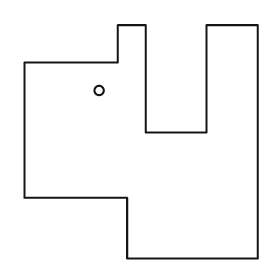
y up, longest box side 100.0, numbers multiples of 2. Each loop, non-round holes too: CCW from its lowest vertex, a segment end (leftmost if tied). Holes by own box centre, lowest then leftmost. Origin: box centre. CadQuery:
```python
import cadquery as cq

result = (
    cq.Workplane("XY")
    .moveTo(-6.0, -50.0)
    .lineTo(50.0, -50.0)
    .lineTo(50.0, 50.0)
    .lineTo(28.0, 50.0)
    .lineTo(28.0, 4.0)
    .lineTo(2.0, 4.0)
    .lineTo(2.0, 50.0)
    .lineTo(-10.0, 50.0)
    .lineTo(-10.0, 34.0)
    .lineTo(-50.0, 34.0)
    .lineTo(-50.0, -24.0)
    .lineTo(-6.0, -24.0)
    .close()
    .moveTo(-18.0, 22.0)
    .circle(2.0)
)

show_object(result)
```